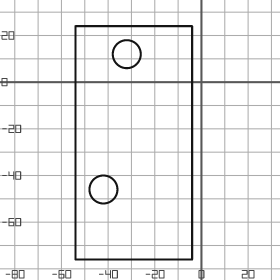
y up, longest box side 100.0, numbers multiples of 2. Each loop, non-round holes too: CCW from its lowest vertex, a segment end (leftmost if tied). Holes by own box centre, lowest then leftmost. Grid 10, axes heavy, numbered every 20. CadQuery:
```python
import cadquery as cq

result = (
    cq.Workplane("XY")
    .moveTo(-54.0, -76.0)
    .lineTo(-4.0, -76.0)
    .lineTo(-4.0, 24.0)
    .lineTo(-54.0, 24.0)
    .close()
    .moveTo(-42.0, -46.0)
    .circle(6.0)
    .moveTo(-32.0, 12.0)
    .circle(6.0)
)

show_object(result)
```